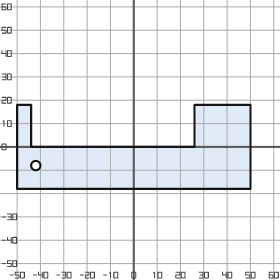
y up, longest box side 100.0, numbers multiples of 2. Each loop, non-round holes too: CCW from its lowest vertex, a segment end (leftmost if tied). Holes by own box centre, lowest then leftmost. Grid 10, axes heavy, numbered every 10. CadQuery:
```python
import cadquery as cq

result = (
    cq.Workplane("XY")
    .moveTo(-50.0, -18.0)
    .lineTo(50.0, -18.0)
    .lineTo(50.0, 18.0)
    .lineTo(26.0, 18.0)
    .lineTo(26.0, 0.0)
    .lineTo(-44.0, 0.0)
    .lineTo(-44.0, 18.0)
    .lineTo(-50.0, 18.0)
    .close()
    .moveTo(-42.0, -8.0)
    .circle(2.0)
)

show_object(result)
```